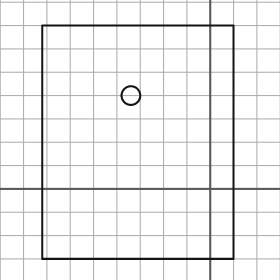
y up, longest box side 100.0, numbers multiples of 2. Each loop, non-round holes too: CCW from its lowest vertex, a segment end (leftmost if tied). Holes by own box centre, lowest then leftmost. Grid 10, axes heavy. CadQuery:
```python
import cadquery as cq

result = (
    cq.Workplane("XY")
    .moveTo(-72.0, -30.0)
    .lineTo(10.0, -30.0)
    .lineTo(10.0, 70.0)
    .lineTo(-72.0, 70.0)
    .close()
    .moveTo(-34.0, 40.0)
    .circle(4.0)
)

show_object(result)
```